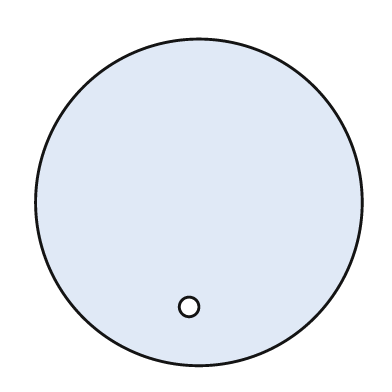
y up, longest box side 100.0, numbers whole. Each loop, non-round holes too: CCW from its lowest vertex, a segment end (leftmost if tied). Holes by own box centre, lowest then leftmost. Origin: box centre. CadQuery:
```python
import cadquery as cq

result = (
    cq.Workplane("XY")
    .moveTo(0.0, 0.0)
    .circle(50.0)
    .moveTo(-3.0, -32.0)
    .circle(3.0)
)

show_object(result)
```